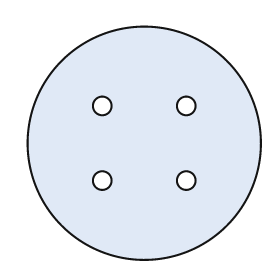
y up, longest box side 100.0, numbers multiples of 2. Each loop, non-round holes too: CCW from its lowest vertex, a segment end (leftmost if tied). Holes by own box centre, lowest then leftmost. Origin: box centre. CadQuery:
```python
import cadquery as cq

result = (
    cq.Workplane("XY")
    .moveTo(0.0, 0.0)
    .circle(50.0)
    .moveTo(-18.0, -16.0)
    .circle(4.0)
    .moveTo(18.0, -16.0)
    .circle(4.0)
    .moveTo(-18.0, 16.0)
    .circle(4.0)
    .moveTo(18.0, 16.0)
    .circle(4.0)
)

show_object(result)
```